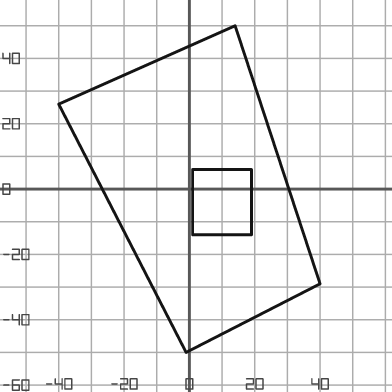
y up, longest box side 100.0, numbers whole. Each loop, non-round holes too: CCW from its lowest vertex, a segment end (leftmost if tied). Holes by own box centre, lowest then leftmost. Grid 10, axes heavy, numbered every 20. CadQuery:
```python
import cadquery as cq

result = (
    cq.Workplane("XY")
    .moveTo(-1.0, -50.0)
    .lineTo(40.0, -29.0)
    .lineTo(14.0, 50.0)
    .lineTo(-40.0, 26.0)
    .close()
    .moveTo(1.0, -14.0)
    .lineTo(19.0, -14.0)
    .lineTo(19.0, 6.0)
    .lineTo(1.0, 6.0)
    .close()
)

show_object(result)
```